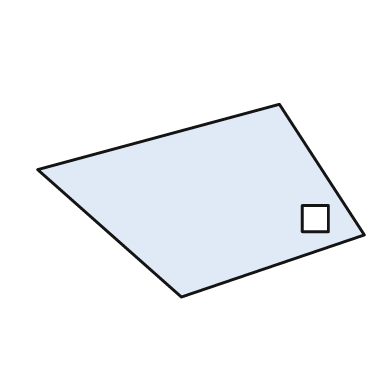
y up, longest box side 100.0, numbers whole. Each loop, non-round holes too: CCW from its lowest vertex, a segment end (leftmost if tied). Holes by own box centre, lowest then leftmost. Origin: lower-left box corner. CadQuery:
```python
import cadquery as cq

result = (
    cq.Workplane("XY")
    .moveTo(44.0, 0.0)
    .lineTo(100.0, 19.0)
    .lineTo(74.0, 59.0)
    .lineTo(0.0, 39.0)
    .close()
    .moveTo(81.0, 20.0)
    .lineTo(89.0, 20.0)
    .lineTo(89.0, 28.0)
    .lineTo(81.0, 28.0)
    .close()
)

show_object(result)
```